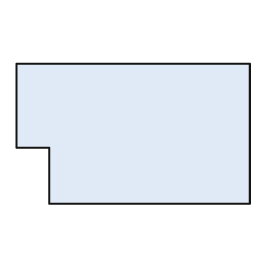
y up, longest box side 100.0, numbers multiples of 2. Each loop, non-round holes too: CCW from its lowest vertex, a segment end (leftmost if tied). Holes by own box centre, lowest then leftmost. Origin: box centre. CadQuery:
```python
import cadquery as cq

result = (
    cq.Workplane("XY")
    .moveTo(-36.0, -30.0)
    .lineTo(50.0, -30.0)
    .lineTo(50.0, 30.0)
    .lineTo(-50.0, 30.0)
    .lineTo(-50.0, -6.0)
    .lineTo(-36.0, -6.0)
    .close()
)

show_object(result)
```